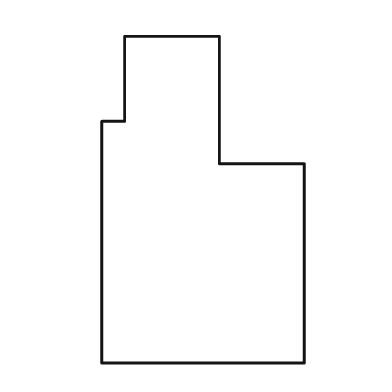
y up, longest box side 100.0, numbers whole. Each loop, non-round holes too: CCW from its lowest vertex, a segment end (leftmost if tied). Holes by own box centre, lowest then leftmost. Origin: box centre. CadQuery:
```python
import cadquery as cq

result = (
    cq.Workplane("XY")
    .moveTo(-31.0, -50.0)
    .lineTo(31.0, -50.0)
    .lineTo(31.0, 11.0)
    .lineTo(5.0, 11.0)
    .lineTo(5.0, 50.0)
    .lineTo(-24.0, 50.0)
    .lineTo(-24.0, 24.0)
    .lineTo(-31.0, 24.0)
    .close()
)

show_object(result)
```